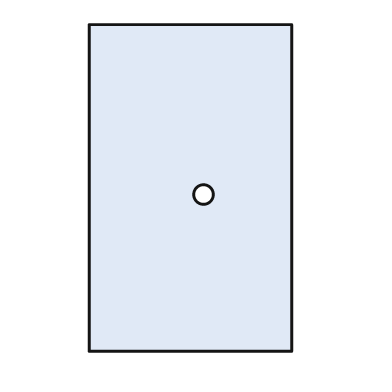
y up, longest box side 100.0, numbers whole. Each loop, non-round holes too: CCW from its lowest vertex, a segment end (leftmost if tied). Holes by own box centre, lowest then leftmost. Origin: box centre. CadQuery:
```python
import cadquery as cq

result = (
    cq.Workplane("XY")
    .moveTo(-31.0, -50.0)
    .lineTo(31.0, -50.0)
    .lineTo(31.0, 50.0)
    .lineTo(-31.0, 50.0)
    .close()
    .moveTo(4.0, -2.0)
    .circle(3.0)
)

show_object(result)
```